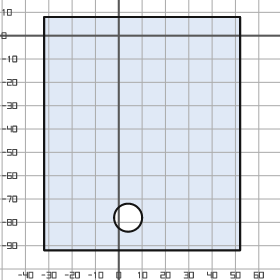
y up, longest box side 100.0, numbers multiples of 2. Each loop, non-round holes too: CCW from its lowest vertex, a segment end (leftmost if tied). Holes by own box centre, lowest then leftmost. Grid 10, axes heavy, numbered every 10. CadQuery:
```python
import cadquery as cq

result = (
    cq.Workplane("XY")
    .moveTo(-32.0, -92.0)
    .lineTo(52.0, -92.0)
    .lineTo(52.0, 8.0)
    .lineTo(-32.0, 8.0)
    .close()
    .moveTo(4.0, -78.0)
    .circle(6.0)
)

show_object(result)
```